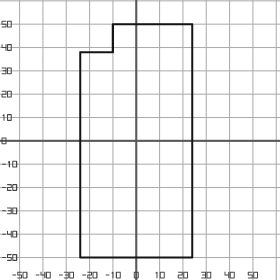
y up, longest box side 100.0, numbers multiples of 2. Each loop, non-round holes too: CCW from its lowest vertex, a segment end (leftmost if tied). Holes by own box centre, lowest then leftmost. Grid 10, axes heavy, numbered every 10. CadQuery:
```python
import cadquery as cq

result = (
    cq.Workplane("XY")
    .moveTo(-24.0, -50.0)
    .lineTo(24.0, -50.0)
    .lineTo(24.0, 50.0)
    .lineTo(-10.0, 50.0)
    .lineTo(-10.0, 38.0)
    .lineTo(-24.0, 38.0)
    .close()
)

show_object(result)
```